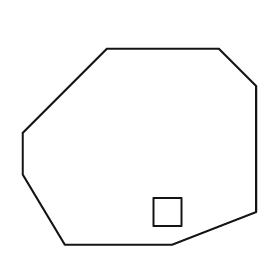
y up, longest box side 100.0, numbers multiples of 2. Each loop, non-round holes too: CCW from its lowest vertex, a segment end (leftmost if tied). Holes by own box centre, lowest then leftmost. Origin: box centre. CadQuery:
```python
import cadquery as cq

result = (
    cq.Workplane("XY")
    .moveTo(-32.0, -42.0)
    .lineTo(14.0, -42.0)
    .lineTo(50.0, -28.0)
    .lineTo(50.0, 26.0)
    .lineTo(34.0, 42.0)
    .lineTo(-14.0, 42.0)
    .lineTo(-50.0, 6.0)
    .lineTo(-50.0, -12.0)
    .close()
    .moveTo(6.0, -34.0)
    .lineTo(18.0, -34.0)
    .lineTo(18.0, -22.0)
    .lineTo(6.0, -22.0)
    .close()
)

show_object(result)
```